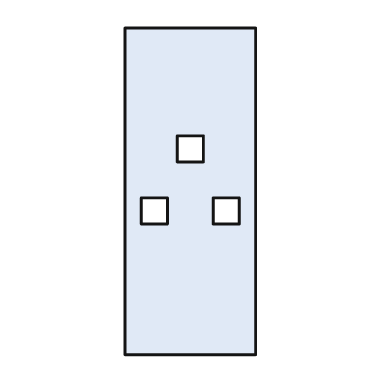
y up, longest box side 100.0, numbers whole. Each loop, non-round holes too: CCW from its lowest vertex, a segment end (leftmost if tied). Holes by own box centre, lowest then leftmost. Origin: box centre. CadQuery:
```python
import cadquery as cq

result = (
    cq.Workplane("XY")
    .moveTo(-20.0, -50.0)
    .lineTo(20.0, -50.0)
    .lineTo(20.0, 50.0)
    .lineTo(-20.0, 50.0)
    .close()
    .moveTo(-15.0, -10.0)
    .lineTo(-7.0, -10.0)
    .lineTo(-7.0, -2.0)
    .lineTo(-15.0, -2.0)
    .close()
    .moveTo(7.0, -10.0)
    .lineTo(15.0, -10.0)
    .lineTo(15.0, -2.0)
    .lineTo(7.0, -2.0)
    .close()
    .moveTo(-4.0, 9.0)
    .lineTo(4.0, 9.0)
    .lineTo(4.0, 17.0)
    .lineTo(-4.0, 17.0)
    .close()
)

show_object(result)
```